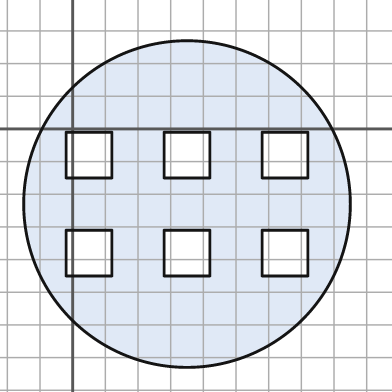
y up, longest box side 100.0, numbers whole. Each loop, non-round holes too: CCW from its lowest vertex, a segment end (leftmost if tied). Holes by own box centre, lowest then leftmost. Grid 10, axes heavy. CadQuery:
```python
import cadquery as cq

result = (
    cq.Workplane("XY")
    .moveTo(35.0, -23.0)
    .circle(50.0)
    .moveTo(-2.0, -45.0)
    .lineTo(12.0, -45.0)
    .lineTo(12.0, -31.0)
    .lineTo(-2.0, -31.0)
    .close()
    .moveTo(28.0, -45.0)
    .lineTo(42.0, -45.0)
    .lineTo(42.0, -31.0)
    .lineTo(28.0, -31.0)
    .close()
    .moveTo(58.0, -45.0)
    .lineTo(72.0, -45.0)
    .lineTo(72.0, -31.0)
    .lineTo(58.0, -31.0)
    .close()
    .moveTo(-2.0, -15.0)
    .lineTo(12.0, -15.0)
    .lineTo(12.0, -1.0)
    .lineTo(-2.0, -1.0)
    .close()
    .moveTo(28.0, -15.0)
    .lineTo(42.0, -15.0)
    .lineTo(42.0, -1.0)
    .lineTo(28.0, -1.0)
    .close()
    .moveTo(58.0, -15.0)
    .lineTo(72.0, -15.0)
    .lineTo(72.0, -1.0)
    .lineTo(58.0, -1.0)
    .close()
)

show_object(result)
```